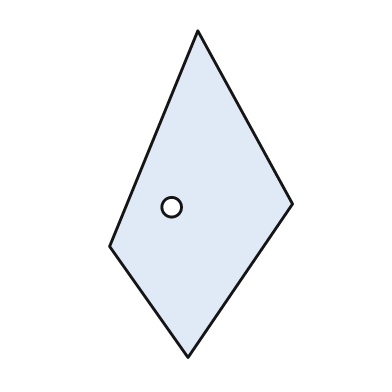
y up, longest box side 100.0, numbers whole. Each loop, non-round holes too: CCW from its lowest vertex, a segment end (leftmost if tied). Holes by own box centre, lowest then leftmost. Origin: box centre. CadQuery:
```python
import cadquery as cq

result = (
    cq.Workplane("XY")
    .moveTo(-4.0, -50.0)
    .lineTo(28.0, -3.0)
    .lineTo(-1.0, 50.0)
    .lineTo(-28.0, -16.0)
    .close()
    .moveTo(-9.0, -4.0)
    .circle(3.0)
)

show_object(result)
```